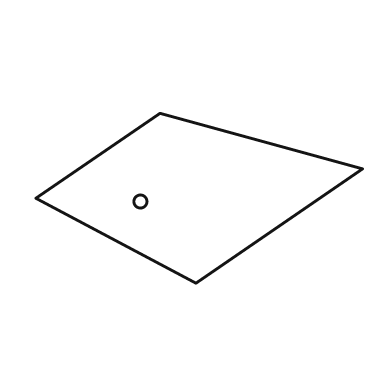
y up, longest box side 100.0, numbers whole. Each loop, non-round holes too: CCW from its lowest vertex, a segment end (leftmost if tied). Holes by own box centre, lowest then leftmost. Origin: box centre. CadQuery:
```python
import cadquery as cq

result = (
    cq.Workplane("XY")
    .moveTo(-1.0, -26.0)
    .lineTo(50.0, 9.0)
    .lineTo(-12.0, 26.0)
    .lineTo(-50.0, 0.0)
    .close()
    .moveTo(-18.0, -1.0)
    .circle(2.0)
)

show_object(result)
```